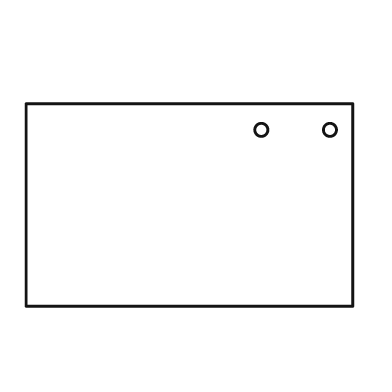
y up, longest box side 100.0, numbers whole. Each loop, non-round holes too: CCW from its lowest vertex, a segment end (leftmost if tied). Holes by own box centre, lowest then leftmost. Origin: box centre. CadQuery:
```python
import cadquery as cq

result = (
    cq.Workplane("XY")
    .moveTo(-50.0, -31.0)
    .lineTo(50.0, -31.0)
    .lineTo(50.0, 31.0)
    .lineTo(-50.0, 31.0)
    .close()
    .moveTo(22.0, 23.0)
    .circle(2.0)
    .moveTo(43.0, 23.0)
    .circle(2.0)
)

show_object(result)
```